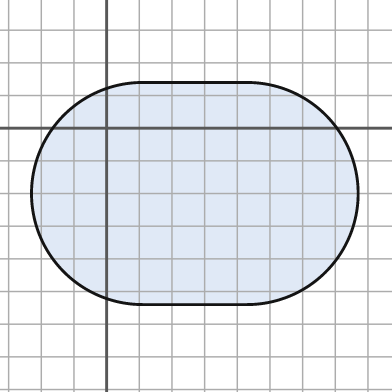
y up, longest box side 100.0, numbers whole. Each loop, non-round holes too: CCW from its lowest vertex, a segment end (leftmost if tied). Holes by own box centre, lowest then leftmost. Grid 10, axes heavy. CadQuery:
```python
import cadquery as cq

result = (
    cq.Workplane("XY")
    .moveTo(11.0, -54.0)
    .lineTo(43.0, -54.0)
    .threePointArc((77.0, -20.0), (43.0, 14.0))
    .lineTo(11.0, 14.0)
    .threePointArc((-23.0, -20.0), (11.0, -54.0))
    .close()
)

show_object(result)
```